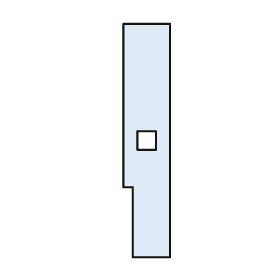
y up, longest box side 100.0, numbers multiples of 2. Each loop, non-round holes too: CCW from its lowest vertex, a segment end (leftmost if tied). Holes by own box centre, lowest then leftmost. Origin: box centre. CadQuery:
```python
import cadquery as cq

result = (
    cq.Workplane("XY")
    .moveTo(-6.0, -50.0)
    .lineTo(10.0, -50.0)
    .lineTo(10.0, 50.0)
    .lineTo(-10.0, 50.0)
    .lineTo(-10.0, -20.0)
    .lineTo(-6.0, -20.0)
    .close()
    .moveTo(-4.0, -4.0)
    .lineTo(4.0, -4.0)
    .lineTo(4.0, 4.0)
    .lineTo(-4.0, 4.0)
    .close()
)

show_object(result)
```